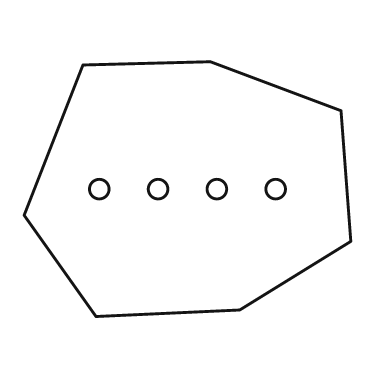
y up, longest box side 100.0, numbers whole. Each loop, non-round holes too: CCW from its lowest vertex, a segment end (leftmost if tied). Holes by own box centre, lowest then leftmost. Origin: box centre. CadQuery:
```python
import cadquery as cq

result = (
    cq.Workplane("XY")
    .moveTo(-28.0, -39.0)
    .lineTo(16.0, -37.0)
    .lineTo(50.0, -16.0)
    .lineTo(47.0, 24.0)
    .lineTo(7.0, 39.0)
    .lineTo(-32.0, 38.0)
    .lineTo(-50.0, -8.0)
    .close()
    .moveTo(-27.0, 0.0)
    .circle(3.0)
    .moveTo(-9.0, 0.0)
    .circle(3.0)
    .moveTo(9.0, 0.0)
    .circle(3.0)
    .moveTo(27.0, 0.0)
    .circle(3.0)
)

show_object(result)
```